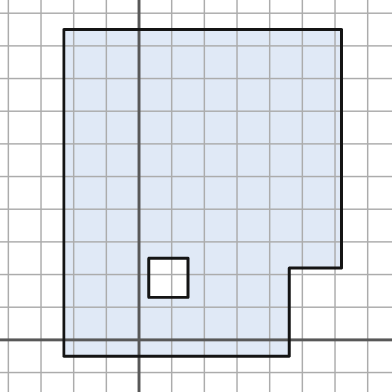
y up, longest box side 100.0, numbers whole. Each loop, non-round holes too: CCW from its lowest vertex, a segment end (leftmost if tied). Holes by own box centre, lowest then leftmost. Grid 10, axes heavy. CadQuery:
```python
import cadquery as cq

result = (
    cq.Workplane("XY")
    .moveTo(-23.0, -5.0)
    .lineTo(46.0, -5.0)
    .lineTo(46.0, 22.0)
    .lineTo(62.0, 22.0)
    .lineTo(62.0, 95.0)
    .lineTo(-23.0, 95.0)
    .close()
    .moveTo(3.0, 13.0)
    .lineTo(15.0, 13.0)
    .lineTo(15.0, 25.0)
    .lineTo(3.0, 25.0)
    .close()
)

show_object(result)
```